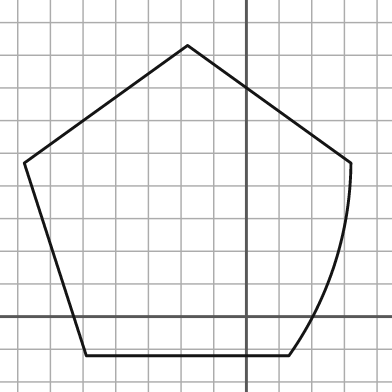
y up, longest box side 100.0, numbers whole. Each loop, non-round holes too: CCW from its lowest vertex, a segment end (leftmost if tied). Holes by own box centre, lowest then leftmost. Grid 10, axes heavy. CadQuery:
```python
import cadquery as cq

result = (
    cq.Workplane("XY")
    .moveTo(-49.0, -12.0)
    .lineTo(13.0, -12.0)
    .threePointArc((27.0, 16.0), (32.0, 47.0))
    .lineTo(-18.0, 83.0)
    .lineTo(-68.0, 47.0)
    .close()
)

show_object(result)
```